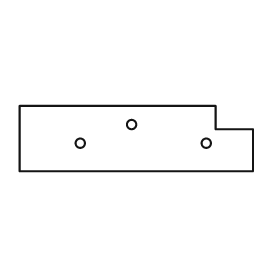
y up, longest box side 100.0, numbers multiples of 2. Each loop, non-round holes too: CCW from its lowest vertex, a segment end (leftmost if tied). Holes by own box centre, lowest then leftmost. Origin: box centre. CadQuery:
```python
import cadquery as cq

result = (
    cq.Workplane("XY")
    .moveTo(-50.0, -14.0)
    .lineTo(50.0, -14.0)
    .lineTo(50.0, 4.0)
    .lineTo(34.0, 4.0)
    .lineTo(34.0, 14.0)
    .lineTo(-50.0, 14.0)
    .close()
    .moveTo(-24.0, -2.0)
    .circle(2.0)
    .moveTo(30.0, -2.0)
    .circle(2.0)
    .moveTo(-2.0, 6.0)
    .circle(2.0)
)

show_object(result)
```